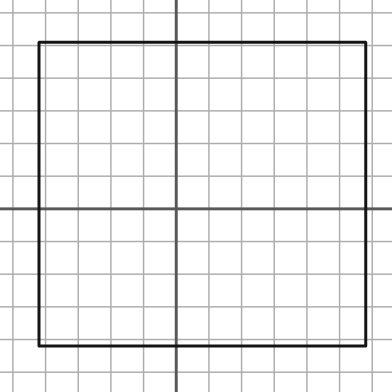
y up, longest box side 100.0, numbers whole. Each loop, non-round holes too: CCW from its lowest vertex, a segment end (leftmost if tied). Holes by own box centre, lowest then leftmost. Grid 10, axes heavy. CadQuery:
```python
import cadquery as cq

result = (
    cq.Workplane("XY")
    .moveTo(-42.0, -42.0)
    .lineTo(58.0, -42.0)
    .lineTo(58.0, 51.0)
    .lineTo(-42.0, 51.0)
    .close()
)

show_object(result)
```